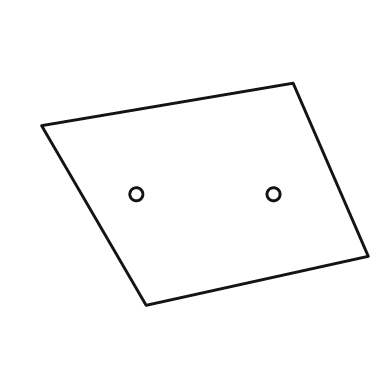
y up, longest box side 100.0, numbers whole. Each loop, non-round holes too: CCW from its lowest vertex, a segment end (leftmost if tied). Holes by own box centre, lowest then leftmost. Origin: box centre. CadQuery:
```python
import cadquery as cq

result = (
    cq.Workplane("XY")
    .moveTo(-18.0, -34.0)
    .lineTo(50.0, -19.0)
    .lineTo(27.0, 34.0)
    .lineTo(-50.0, 21.0)
    .close()
    .moveTo(-21.0, 0.0)
    .circle(2.0)
    .moveTo(21.0, 0.0)
    .circle(2.0)
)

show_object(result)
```